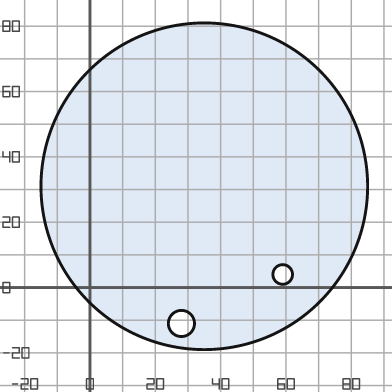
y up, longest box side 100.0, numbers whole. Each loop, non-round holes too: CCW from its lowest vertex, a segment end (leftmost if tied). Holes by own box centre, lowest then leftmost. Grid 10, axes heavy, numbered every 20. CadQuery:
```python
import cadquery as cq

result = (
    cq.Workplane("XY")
    .moveTo(35.0, 31.0)
    .circle(50.0)
    .moveTo(28.0, -11.0)
    .circle(4.0)
    .moveTo(59.0, 4.0)
    .circle(3.0)
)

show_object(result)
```